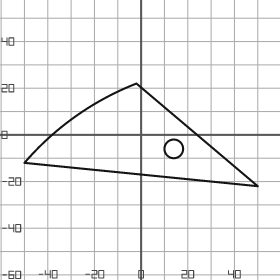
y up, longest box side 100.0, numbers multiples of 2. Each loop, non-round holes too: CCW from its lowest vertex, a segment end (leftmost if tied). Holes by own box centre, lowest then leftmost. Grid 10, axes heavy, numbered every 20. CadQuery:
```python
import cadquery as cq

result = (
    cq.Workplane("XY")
    .moveTo(50.0, -22.0)
    .lineTo(-2.0, 22.0)
    .threePointArc((-28.0, 8.0), (-50.0, -12.0))
    .close()
    .moveTo(14.0, -6.0)
    .circle(4.0)
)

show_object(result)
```